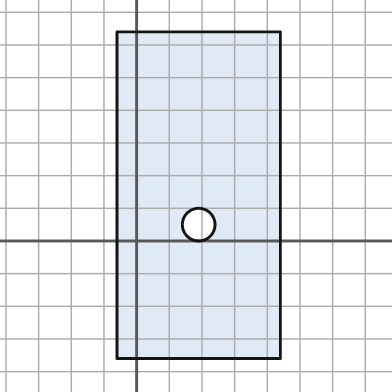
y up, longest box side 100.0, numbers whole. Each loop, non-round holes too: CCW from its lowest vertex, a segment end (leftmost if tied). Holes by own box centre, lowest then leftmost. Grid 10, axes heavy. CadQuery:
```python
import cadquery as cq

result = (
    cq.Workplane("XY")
    .moveTo(-6.0, -36.0)
    .lineTo(44.0, -36.0)
    .lineTo(44.0, 64.0)
    .lineTo(-6.0, 64.0)
    .close()
    .moveTo(19.0, 5.0)
    .circle(5.0)
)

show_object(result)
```